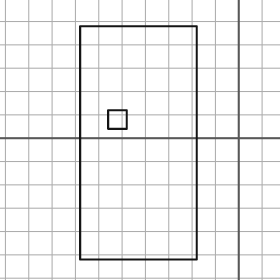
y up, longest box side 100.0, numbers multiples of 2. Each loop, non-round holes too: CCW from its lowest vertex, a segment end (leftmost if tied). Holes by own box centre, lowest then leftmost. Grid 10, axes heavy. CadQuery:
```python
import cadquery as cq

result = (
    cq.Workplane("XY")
    .moveTo(-68.0, -52.0)
    .lineTo(-18.0, -52.0)
    .lineTo(-18.0, 48.0)
    .lineTo(-68.0, 48.0)
    .close()
    .moveTo(-56.0, 4.0)
    .lineTo(-48.0, 4.0)
    .lineTo(-48.0, 12.0)
    .lineTo(-56.0, 12.0)
    .close()
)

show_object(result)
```